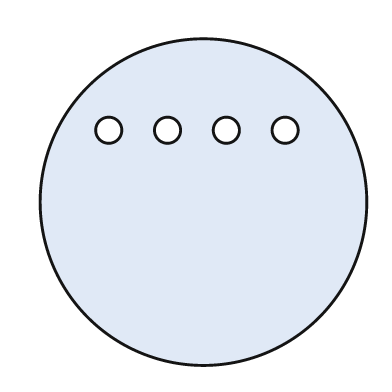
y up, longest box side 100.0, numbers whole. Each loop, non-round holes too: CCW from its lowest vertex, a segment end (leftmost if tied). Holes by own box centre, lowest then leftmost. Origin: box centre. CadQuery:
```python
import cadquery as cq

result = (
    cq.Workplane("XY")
    .moveTo(0.0, 0.0)
    .circle(50.0)
    .moveTo(-29.0, 22.0)
    .circle(4.0)
    .moveTo(-11.0, 22.0)
    .circle(4.0)
    .moveTo(7.0, 22.0)
    .circle(4.0)
    .moveTo(25.0, 22.0)
    .circle(4.0)
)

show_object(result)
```